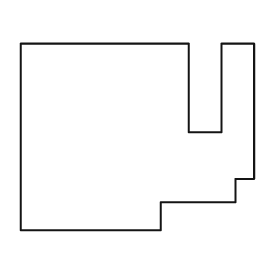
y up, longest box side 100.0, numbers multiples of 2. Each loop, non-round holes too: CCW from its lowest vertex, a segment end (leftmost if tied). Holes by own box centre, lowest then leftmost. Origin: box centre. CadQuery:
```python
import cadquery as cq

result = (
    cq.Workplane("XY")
    .moveTo(-50.0, -40.0)
    .lineTo(10.0, -40.0)
    .lineTo(10.0, -28.0)
    .lineTo(42.0, -28.0)
    .lineTo(42.0, -18.0)
    .lineTo(50.0, -18.0)
    .lineTo(50.0, 40.0)
    .lineTo(36.0, 40.0)
    .lineTo(36.0, 2.0)
    .lineTo(22.0, 2.0)
    .lineTo(22.0, 40.0)
    .lineTo(-50.0, 40.0)
    .close()
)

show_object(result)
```